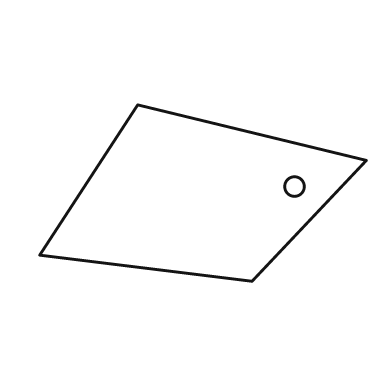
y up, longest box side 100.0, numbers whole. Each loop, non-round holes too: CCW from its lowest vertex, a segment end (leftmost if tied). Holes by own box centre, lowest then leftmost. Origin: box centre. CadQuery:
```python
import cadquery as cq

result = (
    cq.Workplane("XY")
    .moveTo(15.0, -27.0)
    .lineTo(50.0, 10.0)
    .lineTo(-20.0, 27.0)
    .lineTo(-50.0, -19.0)
    .close()
    .moveTo(28.0, 2.0)
    .circle(3.0)
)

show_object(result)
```